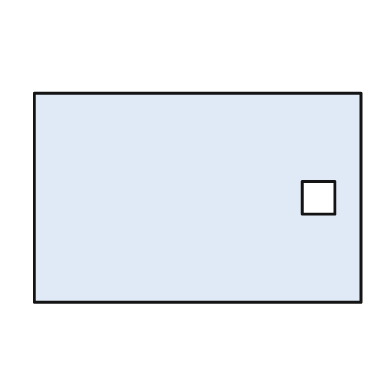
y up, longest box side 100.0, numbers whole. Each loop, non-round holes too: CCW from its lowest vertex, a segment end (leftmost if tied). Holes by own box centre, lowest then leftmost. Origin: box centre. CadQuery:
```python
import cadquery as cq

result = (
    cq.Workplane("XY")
    .moveTo(-50.0, -32.0)
    .lineTo(50.0, -32.0)
    .lineTo(50.0, 32.0)
    .lineTo(-50.0, 32.0)
    .close()
    .moveTo(32.0, -5.0)
    .lineTo(42.0, -5.0)
    .lineTo(42.0, 5.0)
    .lineTo(32.0, 5.0)
    .close()
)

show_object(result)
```